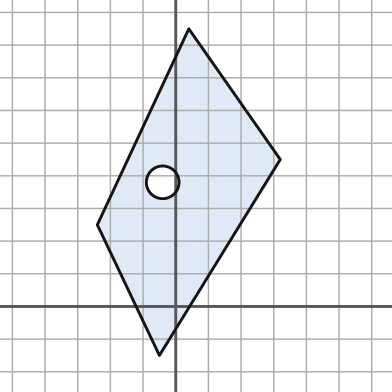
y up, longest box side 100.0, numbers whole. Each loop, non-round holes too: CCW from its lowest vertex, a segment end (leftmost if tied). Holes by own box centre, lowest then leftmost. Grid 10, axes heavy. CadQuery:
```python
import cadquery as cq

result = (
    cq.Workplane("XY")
    .moveTo(-5.0, -15.0)
    .lineTo(32.0, 45.0)
    .lineTo(4.0, 85.0)
    .lineTo(-24.0, 25.0)
    .close()
    .moveTo(-4.0, 38.0)
    .circle(5.0)
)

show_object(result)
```